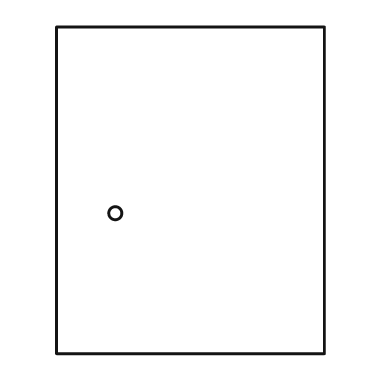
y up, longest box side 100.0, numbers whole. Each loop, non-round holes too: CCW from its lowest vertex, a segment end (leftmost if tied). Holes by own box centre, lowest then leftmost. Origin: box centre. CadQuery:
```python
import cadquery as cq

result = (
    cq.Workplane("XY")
    .moveTo(-41.0, -50.0)
    .lineTo(41.0, -50.0)
    .lineTo(41.0, 50.0)
    .lineTo(-41.0, 50.0)
    .close()
    .moveTo(-23.0, -7.0)
    .circle(2.0)
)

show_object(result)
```